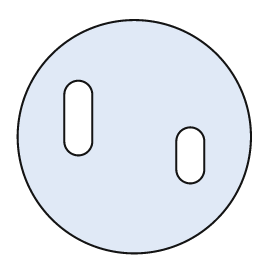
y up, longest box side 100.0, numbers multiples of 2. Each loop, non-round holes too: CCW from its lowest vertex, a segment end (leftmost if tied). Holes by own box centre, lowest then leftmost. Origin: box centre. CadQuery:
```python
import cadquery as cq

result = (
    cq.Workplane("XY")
    .moveTo(0.0, 0.0)
    .circle(50.0)
    .moveTo(18.0, -14.0)
    .threePointArc((24.0, -20.0), (30.0, -14.0))
    .lineTo(30.0, -2.0)
    .threePointArc((24.0, 4.0), (18.0, -2.0))
    .close()
    .moveTo(-30.0, -2.0)
    .threePointArc((-24.0, -8.0), (-18.0, -2.0))
    .lineTo(-18.0, 18.0)
    .threePointArc((-24.0, 24.0), (-30.0, 18.0))
    .close()
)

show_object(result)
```